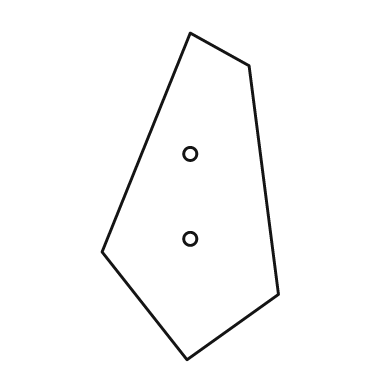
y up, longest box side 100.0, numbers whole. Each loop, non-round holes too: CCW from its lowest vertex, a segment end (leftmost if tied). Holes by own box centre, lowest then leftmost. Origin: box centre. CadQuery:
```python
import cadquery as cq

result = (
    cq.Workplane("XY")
    .moveTo(-1.0, -50.0)
    .lineTo(27.0, -30.0)
    .lineTo(18.0, 40.0)
    .lineTo(0.0, 50.0)
    .lineTo(-27.0, -17.0)
    .close()
    .moveTo(0.0, -13.0)
    .circle(2.0)
    .moveTo(0.0, 13.0)
    .circle(2.0)
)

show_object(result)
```